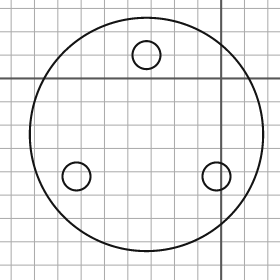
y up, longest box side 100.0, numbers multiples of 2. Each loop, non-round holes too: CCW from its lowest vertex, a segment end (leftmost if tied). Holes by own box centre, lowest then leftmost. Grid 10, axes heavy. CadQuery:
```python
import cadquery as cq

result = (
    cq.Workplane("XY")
    .moveTo(-32.0, -24.0)
    .circle(50.0)
    .moveTo(-62.0, -42.0)
    .circle(6.0)
    .moveTo(-2.0, -42.0)
    .circle(6.0)
    .moveTo(-32.0, 10.0)
    .circle(6.0)
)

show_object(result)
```